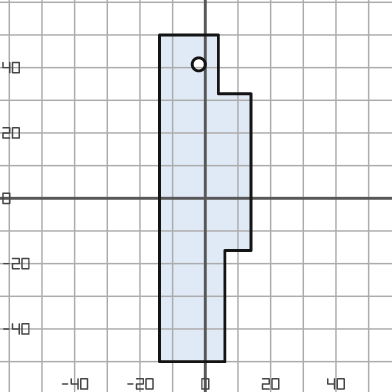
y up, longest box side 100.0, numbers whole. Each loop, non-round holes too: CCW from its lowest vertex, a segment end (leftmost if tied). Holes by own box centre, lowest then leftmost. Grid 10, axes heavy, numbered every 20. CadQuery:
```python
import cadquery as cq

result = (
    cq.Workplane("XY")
    .moveTo(-14.0, -50.0)
    .lineTo(6.0, -50.0)
    .lineTo(6.0, -16.0)
    .lineTo(14.0, -16.0)
    .lineTo(14.0, 32.0)
    .lineTo(4.0, 32.0)
    .lineTo(4.0, 50.0)
    .lineTo(-14.0, 50.0)
    .close()
    .moveTo(-2.0, 41.0)
    .circle(2.0)
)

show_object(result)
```